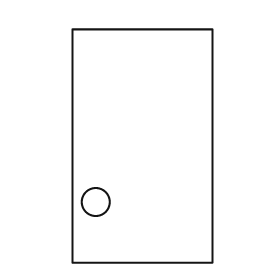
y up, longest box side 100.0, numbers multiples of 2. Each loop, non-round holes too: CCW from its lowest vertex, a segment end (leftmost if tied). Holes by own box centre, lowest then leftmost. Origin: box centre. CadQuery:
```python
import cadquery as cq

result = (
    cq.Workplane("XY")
    .moveTo(-30.0, -50.0)
    .lineTo(30.0, -50.0)
    .lineTo(30.0, 50.0)
    .lineTo(-30.0, 50.0)
    .close()
    .moveTo(-20.0, -24.0)
    .circle(6.0)
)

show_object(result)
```